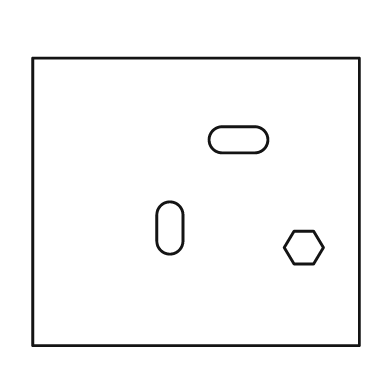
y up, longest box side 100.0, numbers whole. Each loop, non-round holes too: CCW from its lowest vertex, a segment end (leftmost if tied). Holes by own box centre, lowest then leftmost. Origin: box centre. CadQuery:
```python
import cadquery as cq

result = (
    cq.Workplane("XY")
    .moveTo(-50.0, -44.0)
    .lineTo(50.0, -44.0)
    .lineTo(50.0, 44.0)
    .lineTo(-50.0, 44.0)
    .close()
    .moveTo(30.0, -19.0)
    .lineTo(36.0, -19.0)
    .lineTo(39.0, -14.0)
    .lineTo(36.0, -9.0)
    .lineTo(30.0, -9.0)
    .lineTo(27.0, -14.0)
    .close()
    .moveTo(-12.0, -12.0)
    .threePointArc((-8.0, -16.0), (-4.0, -12.0))
    .lineTo(-4.0, -4.0)
    .threePointArc((-8.0, 0.0), (-12.0, -4.0))
    .close()
    .moveTo(8.0, 15.0)
    .lineTo(18.0, 15.0)
    .threePointArc((22.0, 19.0), (18.0, 23.0))
    .lineTo(8.0, 23.0)
    .threePointArc((4.0, 19.0), (8.0, 15.0))
    .close()
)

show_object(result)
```